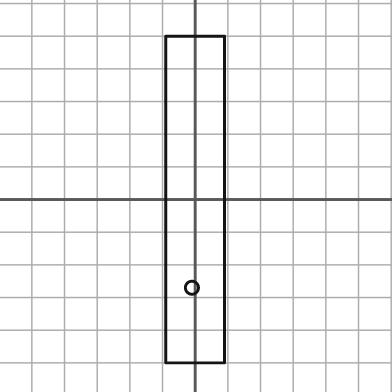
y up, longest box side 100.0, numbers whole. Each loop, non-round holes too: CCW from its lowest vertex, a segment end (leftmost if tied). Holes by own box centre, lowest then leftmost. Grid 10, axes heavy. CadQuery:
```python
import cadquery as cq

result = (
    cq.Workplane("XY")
    .moveTo(-9.0, -50.0)
    .lineTo(9.0, -50.0)
    .lineTo(9.0, 50.0)
    .lineTo(-9.0, 50.0)
    .close()
    .moveTo(-1.0, -27.0)
    .circle(2.0)
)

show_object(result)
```